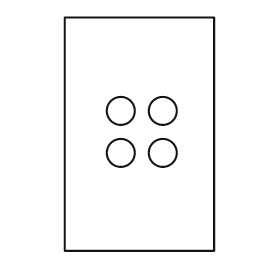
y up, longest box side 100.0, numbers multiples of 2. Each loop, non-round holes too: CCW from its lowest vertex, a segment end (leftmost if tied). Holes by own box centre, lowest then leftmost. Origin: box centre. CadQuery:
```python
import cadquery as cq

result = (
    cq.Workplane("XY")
    .moveTo(-32.0, -50.0)
    .lineTo(32.0, -50.0)
    .lineTo(32.0, 50.0)
    .lineTo(-32.0, 50.0)
    .close()
    .moveTo(-8.0, -8.0)
    .circle(6.0)
    .moveTo(10.0, -8.0)
    .circle(6.0)
    .moveTo(-8.0, 10.0)
    .circle(6.0)
    .moveTo(10.0, 10.0)
    .circle(6.0)
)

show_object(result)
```